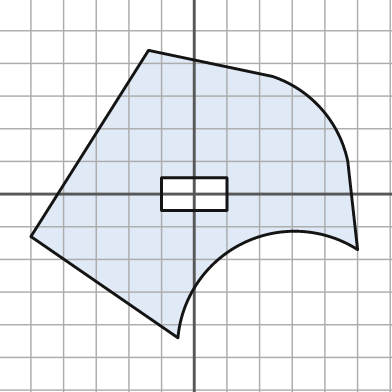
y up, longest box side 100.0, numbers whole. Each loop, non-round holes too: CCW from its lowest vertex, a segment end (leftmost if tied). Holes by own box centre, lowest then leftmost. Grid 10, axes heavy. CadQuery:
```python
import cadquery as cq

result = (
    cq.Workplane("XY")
    .moveTo(-5.0, -44.0)
    .threePointArc((15.0, -15.0), (50.0, -17.0))
    .lineTo(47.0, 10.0)
    .threePointArc((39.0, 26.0), (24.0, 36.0))
    .lineTo(-14.0, 44.0)
    .lineTo(-50.0, -13.0)
    .close()
    .moveTo(-10.0, -5.0)
    .lineTo(10.0, -5.0)
    .lineTo(10.0, 5.0)
    .lineTo(-10.0, 5.0)
    .close()
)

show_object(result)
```